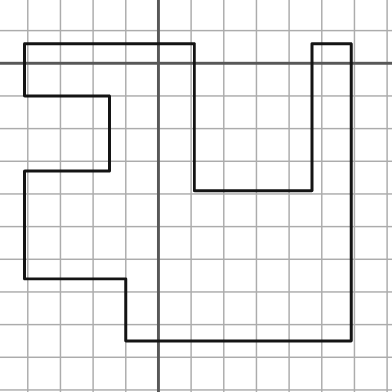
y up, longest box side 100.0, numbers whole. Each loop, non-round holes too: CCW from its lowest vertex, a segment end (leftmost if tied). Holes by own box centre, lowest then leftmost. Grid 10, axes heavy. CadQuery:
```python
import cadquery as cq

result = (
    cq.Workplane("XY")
    .moveTo(-10.0, -85.0)
    .lineTo(59.0, -85.0)
    .lineTo(59.0, 6.0)
    .lineTo(47.0, 6.0)
    .lineTo(47.0, -39.0)
    .lineTo(11.0, -39.0)
    .lineTo(11.0, 6.0)
    .lineTo(-41.0, 6.0)
    .lineTo(-41.0, -10.0)
    .lineTo(-15.0, -10.0)
    .lineTo(-15.0, -33.0)
    .lineTo(-41.0, -33.0)
    .lineTo(-41.0, -66.0)
    .lineTo(-10.0, -66.0)
    .close()
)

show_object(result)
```